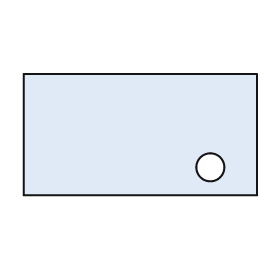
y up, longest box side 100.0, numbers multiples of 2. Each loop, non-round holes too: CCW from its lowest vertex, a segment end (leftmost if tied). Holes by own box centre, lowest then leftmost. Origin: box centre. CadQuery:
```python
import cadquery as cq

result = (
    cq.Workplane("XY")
    .moveTo(-50.0, -26.0)
    .lineTo(50.0, -26.0)
    .lineTo(50.0, 26.0)
    .lineTo(-50.0, 26.0)
    .close()
    .moveTo(30.0, -14.0)
    .circle(6.0)
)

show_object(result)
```